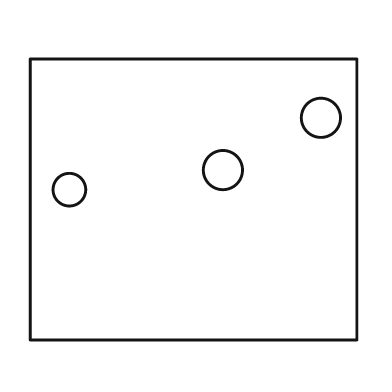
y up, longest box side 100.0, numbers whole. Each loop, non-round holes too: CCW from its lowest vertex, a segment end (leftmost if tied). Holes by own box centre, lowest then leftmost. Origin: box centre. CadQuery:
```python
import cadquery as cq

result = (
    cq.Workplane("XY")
    .moveTo(-50.0, -43.0)
    .lineTo(50.0, -43.0)
    .lineTo(50.0, 43.0)
    .lineTo(-50.0, 43.0)
    .close()
    .moveTo(-38.0, 3.0)
    .circle(5.0)
    .moveTo(9.0, 9.0)
    .circle(6.0)
    .moveTo(39.0, 25.0)
    .circle(6.0)
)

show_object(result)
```